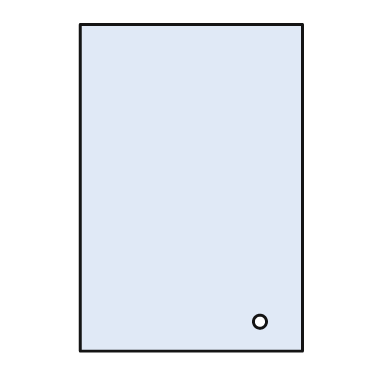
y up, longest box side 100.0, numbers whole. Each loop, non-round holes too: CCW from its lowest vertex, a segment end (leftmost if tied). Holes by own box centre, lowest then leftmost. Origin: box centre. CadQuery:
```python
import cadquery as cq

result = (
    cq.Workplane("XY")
    .moveTo(-34.0, -50.0)
    .lineTo(34.0, -50.0)
    .lineTo(34.0, 50.0)
    .lineTo(-34.0, 50.0)
    .close()
    .moveTo(21.0, -41.0)
    .circle(2.0)
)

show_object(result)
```